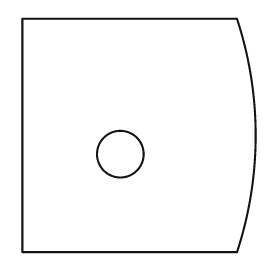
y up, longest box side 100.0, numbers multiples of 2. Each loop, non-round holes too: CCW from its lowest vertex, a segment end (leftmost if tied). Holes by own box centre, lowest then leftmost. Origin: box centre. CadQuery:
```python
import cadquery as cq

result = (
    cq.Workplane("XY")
    .moveTo(-50.0, -50.0)
    .lineTo(42.0, -50.0)
    .threePointArc((50.0, 0.0), (42.0, 50.0))
    .lineTo(-50.0, 50.0)
    .close()
    .moveTo(-8.0, -8.0)
    .circle(10.0)
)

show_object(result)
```